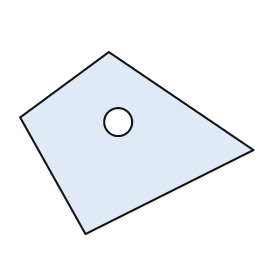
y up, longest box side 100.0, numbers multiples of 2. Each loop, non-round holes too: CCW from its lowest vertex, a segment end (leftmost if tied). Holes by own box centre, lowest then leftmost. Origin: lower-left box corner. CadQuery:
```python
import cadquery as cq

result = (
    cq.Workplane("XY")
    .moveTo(28.0, 0.0)
    .lineTo(100.0, 36.0)
    .lineTo(38.0, 78.0)
    .lineTo(0.0, 50.0)
    .close()
    .moveTo(42.0, 48.0)
    .circle(6.0)
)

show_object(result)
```